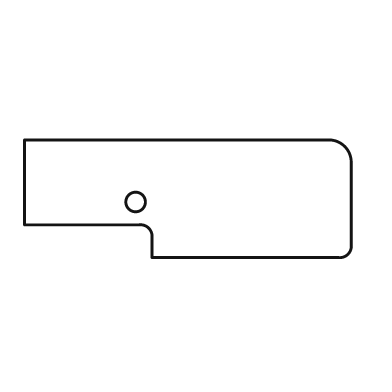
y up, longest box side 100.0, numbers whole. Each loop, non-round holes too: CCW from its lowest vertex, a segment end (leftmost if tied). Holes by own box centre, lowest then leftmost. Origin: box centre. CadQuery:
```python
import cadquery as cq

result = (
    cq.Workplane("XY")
    .moveTo(-11.0, -18.0)
    .lineTo(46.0, -18.0)
    .threePointArc((49.0, -17.0), (50.0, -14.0))
    .lineTo(50.0, 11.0)
    .threePointArc((48.0, 16.0), (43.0, 18.0))
    .lineTo(-50.0, 18.0)
    .lineTo(-50.0, -8.0)
    .lineTo(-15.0, -8.0)
    .threePointArc((-12.0, -9.0), (-11.0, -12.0))
    .close()
    .moveTo(-16.0, -1.0)
    .circle(3.0)
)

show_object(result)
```